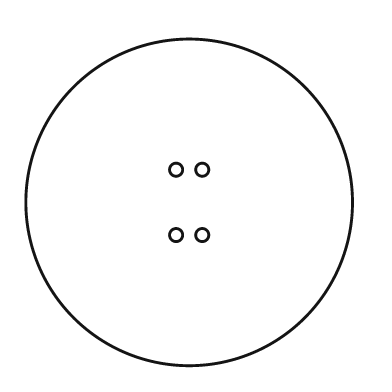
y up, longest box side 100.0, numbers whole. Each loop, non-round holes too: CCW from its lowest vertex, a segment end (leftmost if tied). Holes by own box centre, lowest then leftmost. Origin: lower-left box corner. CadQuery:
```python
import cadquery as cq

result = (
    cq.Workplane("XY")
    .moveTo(50.0, 50.0)
    .circle(50.0)
    .moveTo(46.0, 40.0)
    .circle(2.0)
    .moveTo(54.0, 40.0)
    .circle(2.0)
    .moveTo(46.0, 60.0)
    .circle(2.0)
    .moveTo(54.0, 60.0)
    .circle(2.0)
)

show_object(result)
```